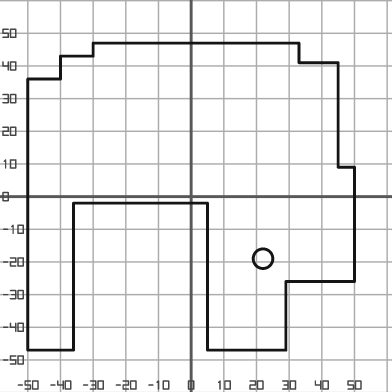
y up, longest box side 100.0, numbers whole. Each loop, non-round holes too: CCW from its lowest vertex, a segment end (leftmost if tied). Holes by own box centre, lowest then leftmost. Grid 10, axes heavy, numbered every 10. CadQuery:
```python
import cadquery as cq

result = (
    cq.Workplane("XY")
    .moveTo(-50.0, -47.0)
    .lineTo(-36.0, -47.0)
    .lineTo(-36.0, -2.0)
    .lineTo(5.0, -2.0)
    .lineTo(5.0, -47.0)
    .lineTo(29.0, -47.0)
    .lineTo(29.0, -26.0)
    .lineTo(50.0, -26.0)
    .lineTo(50.0, 9.0)
    .lineTo(45.0, 9.0)
    .lineTo(45.0, 41.0)
    .lineTo(33.0, 41.0)
    .lineTo(33.0, 47.0)
    .lineTo(-30.0, 47.0)
    .lineTo(-30.0, 43.0)
    .lineTo(-40.0, 43.0)
    .lineTo(-40.0, 36.0)
    .lineTo(-50.0, 36.0)
    .close()
    .moveTo(22.0, -19.0)
    .circle(3.0)
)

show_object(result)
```